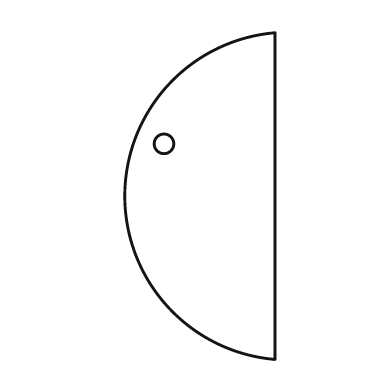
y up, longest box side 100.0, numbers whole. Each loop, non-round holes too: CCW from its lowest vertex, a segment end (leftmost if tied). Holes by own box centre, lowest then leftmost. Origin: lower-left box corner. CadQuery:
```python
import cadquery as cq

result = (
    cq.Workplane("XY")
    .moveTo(46.0, 0.0)
    .lineTo(46.0, 100.0)
    .threePointArc((0.0, 50.0), (46.0, 0.0))
    .close()
    .moveTo(12.0, 66.0)
    .circle(3.0)
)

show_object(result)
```